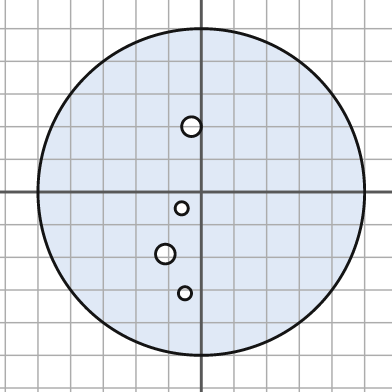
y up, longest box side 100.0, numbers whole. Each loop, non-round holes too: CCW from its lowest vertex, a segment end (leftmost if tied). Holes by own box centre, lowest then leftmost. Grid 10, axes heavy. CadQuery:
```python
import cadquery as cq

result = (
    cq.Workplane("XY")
    .moveTo(0.0, 0.0)
    .circle(50.0)
    .moveTo(-5.0, -31.0)
    .circle(2.0)
    .moveTo(-11.0, -19.0)
    .circle(3.0)
    .moveTo(-6.0, -5.0)
    .circle(2.0)
    .moveTo(-3.0, 20.0)
    .circle(3.0)
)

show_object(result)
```